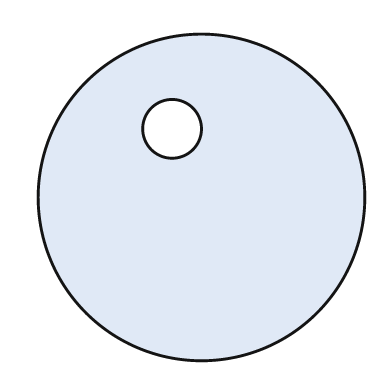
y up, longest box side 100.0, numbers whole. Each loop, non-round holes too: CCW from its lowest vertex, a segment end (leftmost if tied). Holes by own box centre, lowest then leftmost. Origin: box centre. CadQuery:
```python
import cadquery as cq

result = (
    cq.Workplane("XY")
    .moveTo(0.0, 0.0)
    .circle(50.0)
    .moveTo(-9.0, 21.0)
    .circle(9.0)
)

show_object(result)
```